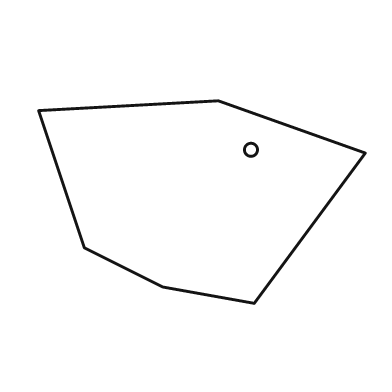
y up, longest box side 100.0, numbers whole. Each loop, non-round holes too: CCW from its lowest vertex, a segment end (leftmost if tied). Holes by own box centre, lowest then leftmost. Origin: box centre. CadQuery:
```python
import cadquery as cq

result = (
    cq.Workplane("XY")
    .moveTo(16.0, -31.0)
    .lineTo(50.0, 15.0)
    .lineTo(5.0, 31.0)
    .lineTo(-50.0, 28.0)
    .lineTo(-36.0, -14.0)
    .lineTo(-12.0, -26.0)
    .close()
    .moveTo(15.0, 16.0)
    .circle(2.0)
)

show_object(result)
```